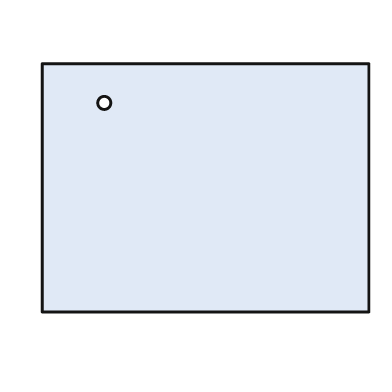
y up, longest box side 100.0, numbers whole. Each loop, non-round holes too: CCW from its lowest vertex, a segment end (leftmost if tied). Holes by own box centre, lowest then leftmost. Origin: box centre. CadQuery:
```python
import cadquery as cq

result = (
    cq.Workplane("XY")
    .moveTo(-50.0, -38.0)
    .lineTo(50.0, -38.0)
    .lineTo(50.0, 38.0)
    .lineTo(-50.0, 38.0)
    .close()
    .moveTo(-31.0, 26.0)
    .circle(2.0)
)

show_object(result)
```